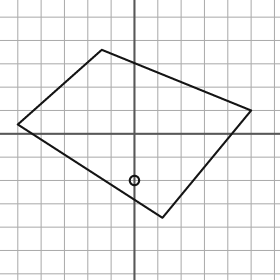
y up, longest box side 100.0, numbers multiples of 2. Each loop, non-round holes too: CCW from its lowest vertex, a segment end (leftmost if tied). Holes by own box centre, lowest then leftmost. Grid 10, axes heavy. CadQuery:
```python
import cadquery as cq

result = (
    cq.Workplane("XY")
    .moveTo(12.0, -36.0)
    .lineTo(50.0, 10.0)
    .lineTo(-14.0, 36.0)
    .lineTo(-50.0, 4.0)
    .close()
    .moveTo(0.0, -20.0)
    .circle(2.0)
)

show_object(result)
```